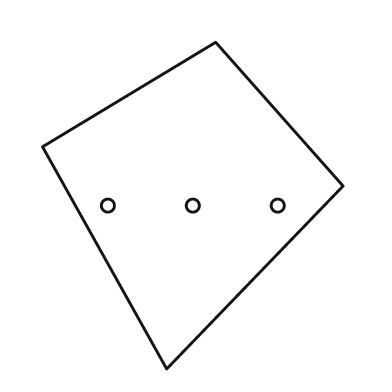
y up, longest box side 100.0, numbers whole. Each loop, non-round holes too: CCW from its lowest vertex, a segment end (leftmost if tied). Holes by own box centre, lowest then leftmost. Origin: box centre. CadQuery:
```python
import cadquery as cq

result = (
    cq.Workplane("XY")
    .moveTo(-8.0, -50.0)
    .lineTo(46.0, 6.0)
    .lineTo(7.0, 50.0)
    .lineTo(-46.0, 18.0)
    .close()
    .moveTo(-26.0, 0.0)
    .circle(2.0)
    .moveTo(0.0, 0.0)
    .circle(2.0)
    .moveTo(26.0, 0.0)
    .circle(2.0)
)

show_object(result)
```